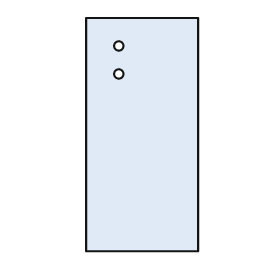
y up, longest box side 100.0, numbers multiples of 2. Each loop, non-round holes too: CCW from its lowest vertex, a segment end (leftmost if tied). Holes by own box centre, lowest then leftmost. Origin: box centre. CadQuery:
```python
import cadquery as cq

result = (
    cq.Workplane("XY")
    .moveTo(-24.0, -50.0)
    .lineTo(24.0, -50.0)
    .lineTo(24.0, 50.0)
    .lineTo(-24.0, 50.0)
    .close()
    .moveTo(-10.0, 26.0)
    .circle(2.0)
    .moveTo(-10.0, 38.0)
    .circle(2.0)
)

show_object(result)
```